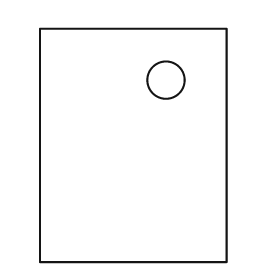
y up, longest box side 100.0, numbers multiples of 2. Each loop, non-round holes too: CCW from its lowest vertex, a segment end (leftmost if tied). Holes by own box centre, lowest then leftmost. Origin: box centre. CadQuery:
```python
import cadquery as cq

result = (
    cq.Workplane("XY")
    .moveTo(-40.0, -50.0)
    .lineTo(40.0, -50.0)
    .lineTo(40.0, 50.0)
    .lineTo(-40.0, 50.0)
    .close()
    .moveTo(14.0, 28.0)
    .circle(8.0)
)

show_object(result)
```